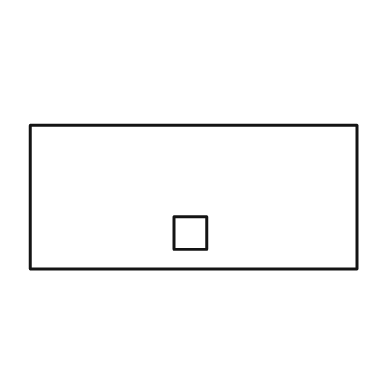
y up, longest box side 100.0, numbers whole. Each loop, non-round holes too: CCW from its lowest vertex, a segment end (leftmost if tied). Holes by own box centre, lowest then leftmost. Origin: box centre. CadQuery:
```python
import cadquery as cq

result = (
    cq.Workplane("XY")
    .moveTo(-50.0, -22.0)
    .lineTo(50.0, -22.0)
    .lineTo(50.0, 22.0)
    .lineTo(-50.0, 22.0)
    .close()
    .moveTo(-6.0, -16.0)
    .lineTo(4.0, -16.0)
    .lineTo(4.0, -6.0)
    .lineTo(-6.0, -6.0)
    .close()
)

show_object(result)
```